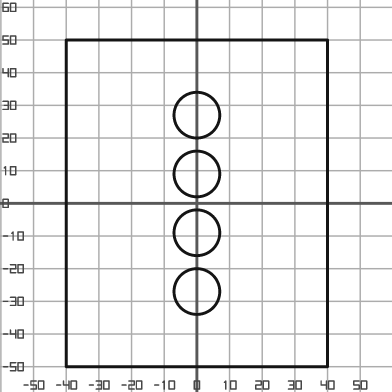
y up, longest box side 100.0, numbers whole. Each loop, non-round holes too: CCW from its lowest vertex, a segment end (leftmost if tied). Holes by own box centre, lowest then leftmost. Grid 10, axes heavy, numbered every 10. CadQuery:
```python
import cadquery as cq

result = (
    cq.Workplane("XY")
    .moveTo(-40.0, -50.0)
    .lineTo(40.0, -50.0)
    .lineTo(40.0, 50.0)
    .lineTo(-40.0, 50.0)
    .close()
    .moveTo(0.0, -27.0)
    .circle(7.0)
    .moveTo(0.0, -9.0)
    .circle(7.0)
    .moveTo(0.0, 9.0)
    .circle(7.0)
    .moveTo(0.0, 27.0)
    .circle(7.0)
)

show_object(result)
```